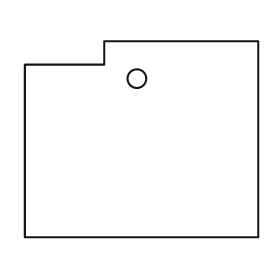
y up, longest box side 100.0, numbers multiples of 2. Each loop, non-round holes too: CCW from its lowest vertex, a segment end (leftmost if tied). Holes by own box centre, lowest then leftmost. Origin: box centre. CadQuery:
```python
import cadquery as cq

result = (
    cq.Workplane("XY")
    .moveTo(-50.0, -42.0)
    .lineTo(50.0, -42.0)
    .lineTo(50.0, 42.0)
    .lineTo(-16.0, 42.0)
    .lineTo(-16.0, 32.0)
    .lineTo(-50.0, 32.0)
    .close()
    .moveTo(-2.0, 26.0)
    .circle(4.0)
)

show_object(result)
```